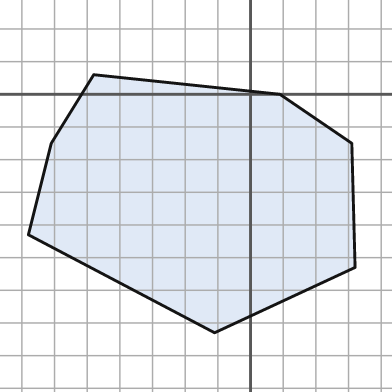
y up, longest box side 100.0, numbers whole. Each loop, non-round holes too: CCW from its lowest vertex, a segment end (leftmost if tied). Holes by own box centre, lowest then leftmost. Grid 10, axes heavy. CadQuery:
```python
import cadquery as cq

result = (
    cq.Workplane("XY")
    .moveTo(-11.0, -73.0)
    .lineTo(32.0, -53.0)
    .lineTo(31.0, -15.0)
    .lineTo(9.0, 0.0)
    .lineTo(-48.0, 6.0)
    .lineTo(-61.0, -15.0)
    .lineTo(-68.0, -43.0)
    .close()
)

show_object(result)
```